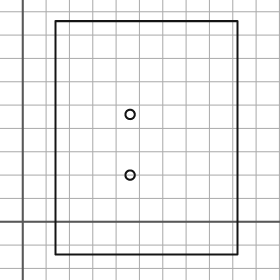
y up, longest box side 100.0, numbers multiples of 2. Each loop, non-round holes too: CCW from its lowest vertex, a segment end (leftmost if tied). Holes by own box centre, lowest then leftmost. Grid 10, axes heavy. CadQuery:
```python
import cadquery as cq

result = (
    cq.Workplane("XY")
    .moveTo(14.0, -14.0)
    .lineTo(92.0, -14.0)
    .lineTo(92.0, 86.0)
    .lineTo(14.0, 86.0)
    .close()
    .moveTo(46.0, 20.0)
    .circle(2.0)
    .moveTo(46.0, 46.0)
    .circle(2.0)
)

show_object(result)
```